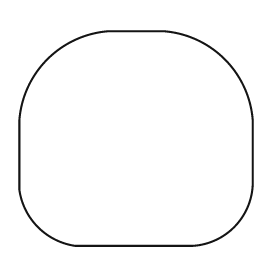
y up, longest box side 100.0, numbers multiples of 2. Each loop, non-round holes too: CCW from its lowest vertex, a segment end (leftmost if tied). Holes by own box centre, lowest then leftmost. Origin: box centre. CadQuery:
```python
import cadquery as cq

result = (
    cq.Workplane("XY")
    .moveTo(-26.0, -46.0)
    .lineTo(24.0, -46.0)
    .threePointArc((42.0, -38.0), (50.0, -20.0))
    .lineTo(50.0, 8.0)
    .threePointArc((38.0, 34.0), (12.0, 46.0))
    .lineTo(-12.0, 46.0)
    .threePointArc((-38.0, 34.0), (-50.0, 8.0))
    .lineTo(-50.0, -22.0)
    .threePointArc((-42.0, -38.0), (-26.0, -46.0))
    .close()
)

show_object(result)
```